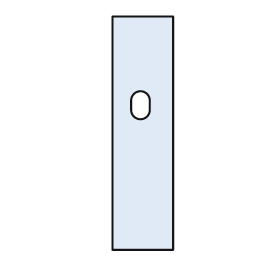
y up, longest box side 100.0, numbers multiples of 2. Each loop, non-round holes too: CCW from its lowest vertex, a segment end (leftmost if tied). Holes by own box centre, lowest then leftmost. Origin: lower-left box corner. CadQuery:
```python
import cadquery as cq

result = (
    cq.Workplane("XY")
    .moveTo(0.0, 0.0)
    .lineTo(26.0, 0.0)
    .lineTo(26.0, 100.0)
    .lineTo(0.0, 100.0)
    .close()
    .moveTo(8.0, 60.0)
    .threePointArc((12.0, 56.0), (16.0, 60.0))
    .lineTo(16.0, 64.0)
    .threePointArc((12.0, 68.0), (8.0, 64.0))
    .close()
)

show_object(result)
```